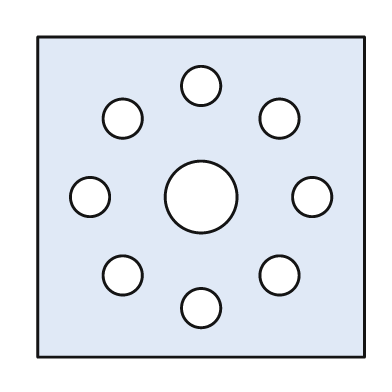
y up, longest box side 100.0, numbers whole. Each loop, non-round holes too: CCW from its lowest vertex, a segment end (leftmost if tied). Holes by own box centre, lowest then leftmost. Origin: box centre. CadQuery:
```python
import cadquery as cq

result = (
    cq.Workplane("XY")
    .moveTo(-50.0, -49.0)
    .lineTo(50.0, -49.0)
    .lineTo(50.0, 49.0)
    .lineTo(-50.0, 49.0)
    .close()
    .moveTo(0.0, -34.0)
    .circle(6.0)
    .moveTo(-24.0, -24.0)
    .circle(6.0)
    .moveTo(24.0, -24.0)
    .circle(6.0)
    .moveTo(-34.0, 0.0)
    .circle(6.0)
    .moveTo(0.0, 0.0)
    .circle(11.0)
    .moveTo(34.0, 0.0)
    .circle(6.0)
    .moveTo(-24.0, 24.0)
    .circle(6.0)
    .moveTo(24.0, 24.0)
    .circle(6.0)
    .moveTo(0.0, 34.0)
    .circle(6.0)
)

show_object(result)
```